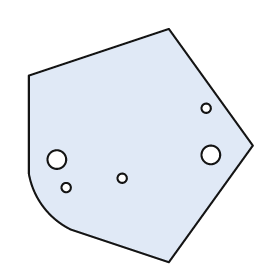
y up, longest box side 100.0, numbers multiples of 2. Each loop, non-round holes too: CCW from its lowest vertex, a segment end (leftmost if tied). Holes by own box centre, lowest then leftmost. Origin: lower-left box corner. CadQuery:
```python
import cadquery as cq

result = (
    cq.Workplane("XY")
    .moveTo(60.0, 0.0)
    .lineTo(96.0, 50.0)
    .lineTo(60.0, 100.0)
    .lineTo(0.0, 80.0)
    .lineTo(0.0, 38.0)
    .threePointArc((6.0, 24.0), (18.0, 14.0))
    .close()
    .moveTo(16.0, 32.0)
    .circle(2.0)
    .moveTo(40.0, 36.0)
    .circle(2.0)
    .moveTo(12.0, 44.0)
    .circle(4.0)
    .moveTo(78.0, 46.0)
    .circle(4.0)
    .moveTo(76.0, 66.0)
    .circle(2.0)
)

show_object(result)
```